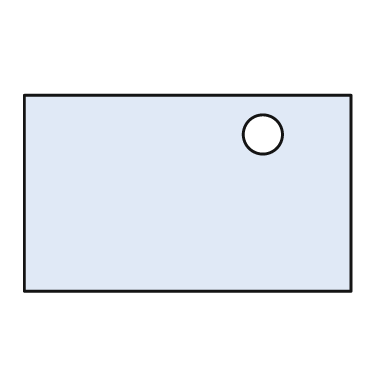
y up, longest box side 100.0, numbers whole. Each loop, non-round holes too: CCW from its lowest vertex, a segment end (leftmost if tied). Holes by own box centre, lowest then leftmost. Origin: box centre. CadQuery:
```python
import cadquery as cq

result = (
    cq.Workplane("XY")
    .moveTo(-50.0, -30.0)
    .lineTo(50.0, -30.0)
    .lineTo(50.0, 30.0)
    .lineTo(-50.0, 30.0)
    .close()
    .moveTo(23.0, 18.0)
    .circle(6.0)
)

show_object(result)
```